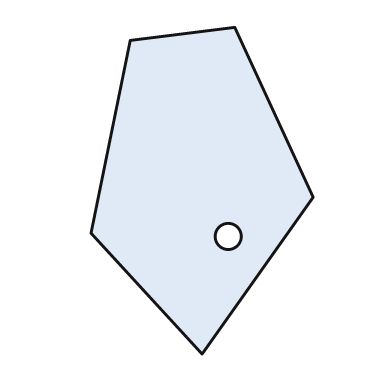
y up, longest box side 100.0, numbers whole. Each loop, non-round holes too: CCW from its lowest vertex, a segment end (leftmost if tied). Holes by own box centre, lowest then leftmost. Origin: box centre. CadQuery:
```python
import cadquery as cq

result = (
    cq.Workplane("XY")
    .moveTo(0.0, -50.0)
    .lineTo(34.0, -2.0)
    .lineTo(10.0, 50.0)
    .lineTo(-22.0, 46.0)
    .lineTo(-34.0, -13.0)
    .close()
    .moveTo(8.0, -14.0)
    .circle(4.0)
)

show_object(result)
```